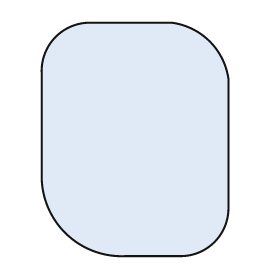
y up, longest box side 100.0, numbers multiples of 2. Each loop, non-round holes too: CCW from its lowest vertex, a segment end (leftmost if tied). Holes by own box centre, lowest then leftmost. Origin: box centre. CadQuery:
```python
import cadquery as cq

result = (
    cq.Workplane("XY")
    .moveTo(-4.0, -50.0)
    .lineTo(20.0, -50.0)
    .threePointArc((34.0, -44.0), (40.0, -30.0))
    .lineTo(40.0, 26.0)
    .threePointArc((32.0, 42.0), (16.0, 50.0))
    .lineTo(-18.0, 50.0)
    .threePointArc((-34.0, 44.0), (-40.0, 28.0))
    .lineTo(-40.0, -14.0)
    .threePointArc((-30.0, -40.0), (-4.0, -50.0))
    .close()
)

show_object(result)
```